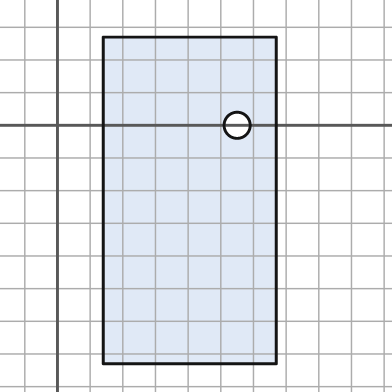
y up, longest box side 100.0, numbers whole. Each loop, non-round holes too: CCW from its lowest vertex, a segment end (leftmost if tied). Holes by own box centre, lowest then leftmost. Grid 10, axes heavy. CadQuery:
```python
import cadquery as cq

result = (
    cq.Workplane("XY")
    .moveTo(14.0, -73.0)
    .lineTo(67.0, -73.0)
    .lineTo(67.0, 27.0)
    .lineTo(14.0, 27.0)
    .close()
    .moveTo(55.0, 0.0)
    .circle(4.0)
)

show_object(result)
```